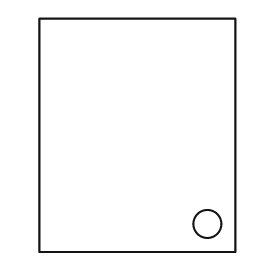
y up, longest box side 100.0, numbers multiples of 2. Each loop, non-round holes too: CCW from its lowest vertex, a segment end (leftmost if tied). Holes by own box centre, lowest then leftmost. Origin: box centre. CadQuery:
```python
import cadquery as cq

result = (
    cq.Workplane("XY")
    .moveTo(-42.0, -50.0)
    .lineTo(42.0, -50.0)
    .lineTo(42.0, 50.0)
    .lineTo(-42.0, 50.0)
    .close()
    .moveTo(30.0, -38.0)
    .circle(6.0)
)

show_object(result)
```